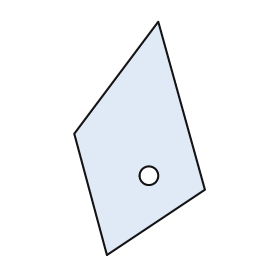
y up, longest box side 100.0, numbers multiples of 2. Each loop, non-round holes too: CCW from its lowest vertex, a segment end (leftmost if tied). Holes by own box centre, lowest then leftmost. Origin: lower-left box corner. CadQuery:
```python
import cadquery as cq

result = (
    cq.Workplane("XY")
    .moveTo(14.0, 0.0)
    .lineTo(56.0, 28.0)
    .lineTo(36.0, 100.0)
    .lineTo(0.0, 52.0)
    .close()
    .moveTo(32.0, 34.0)
    .circle(4.0)
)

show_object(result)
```